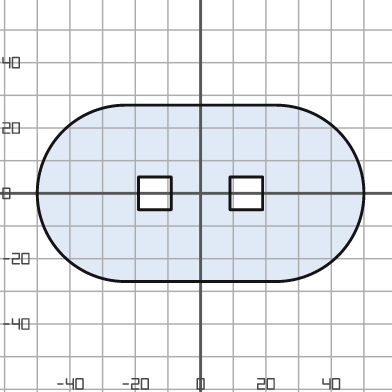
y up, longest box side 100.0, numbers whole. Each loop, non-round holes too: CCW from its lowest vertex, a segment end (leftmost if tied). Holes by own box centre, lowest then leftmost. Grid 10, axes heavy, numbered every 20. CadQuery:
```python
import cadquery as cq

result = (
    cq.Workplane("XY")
    .moveTo(-23.0, -27.0)
    .lineTo(23.0, -27.0)
    .threePointArc((50.0, 0.0), (23.0, 27.0))
    .lineTo(-23.0, 27.0)
    .threePointArc((-50.0, 0.0), (-23.0, -27.0))
    .close()
    .moveTo(-19.0, -5.0)
    .lineTo(-9.0, -5.0)
    .lineTo(-9.0, 5.0)
    .lineTo(-19.0, 5.0)
    .close()
    .moveTo(9.0, -5.0)
    .lineTo(19.0, -5.0)
    .lineTo(19.0, 5.0)
    .lineTo(9.0, 5.0)
    .close()
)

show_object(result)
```